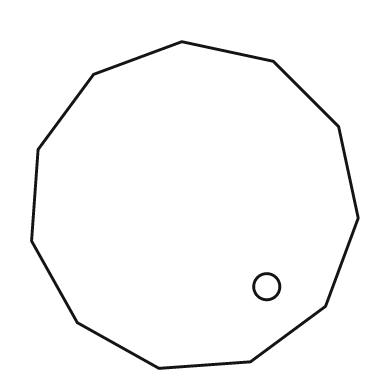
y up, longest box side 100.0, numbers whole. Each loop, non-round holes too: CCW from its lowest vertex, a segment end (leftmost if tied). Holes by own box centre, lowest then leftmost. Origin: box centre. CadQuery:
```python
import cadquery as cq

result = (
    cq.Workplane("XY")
    .moveTo(-11.0, -50.0)
    .lineTo(17.0, -48.0)
    .lineTo(40.0, -31.0)
    .lineTo(50.0, -4.0)
    .lineTo(44.0, 24.0)
    .lineTo(24.0, 44.0)
    .lineTo(-4.0, 50.0)
    .lineTo(-31.0, 40.0)
    .lineTo(-48.0, 17.0)
    .lineTo(-50.0, -11.0)
    .lineTo(-36.0, -36.0)
    .close()
    .moveTo(22.0, -25.0)
    .circle(4.0)
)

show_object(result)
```